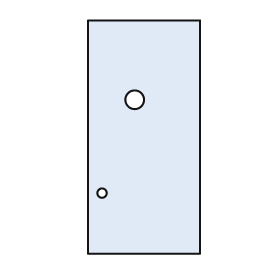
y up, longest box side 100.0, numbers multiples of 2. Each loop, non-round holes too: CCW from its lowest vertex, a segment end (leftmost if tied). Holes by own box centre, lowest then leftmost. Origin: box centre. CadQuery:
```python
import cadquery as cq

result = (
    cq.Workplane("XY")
    .moveTo(-24.0, -50.0)
    .lineTo(24.0, -50.0)
    .lineTo(24.0, 50.0)
    .lineTo(-24.0, 50.0)
    .close()
    .moveTo(-18.0, -24.0)
    .circle(2.0)
    .moveTo(-4.0, 16.0)
    .circle(4.0)
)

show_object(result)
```